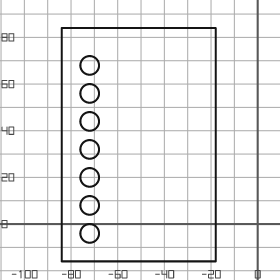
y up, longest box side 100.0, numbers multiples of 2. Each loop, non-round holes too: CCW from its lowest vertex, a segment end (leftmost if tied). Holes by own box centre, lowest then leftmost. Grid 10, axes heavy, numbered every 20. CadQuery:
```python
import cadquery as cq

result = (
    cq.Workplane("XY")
    .moveTo(-84.0, -16.0)
    .lineTo(-18.0, -16.0)
    .lineTo(-18.0, 84.0)
    .lineTo(-84.0, 84.0)
    .close()
    .moveTo(-72.0, -4.0)
    .circle(4.0)
    .moveTo(-72.0, 8.0)
    .circle(4.0)
    .moveTo(-72.0, 20.0)
    .circle(4.0)
    .moveTo(-72.0, 32.0)
    .circle(4.0)
    .moveTo(-72.0, 44.0)
    .circle(4.0)
    .moveTo(-72.0, 56.0)
    .circle(4.0)
    .moveTo(-72.0, 68.0)
    .circle(4.0)
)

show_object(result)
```